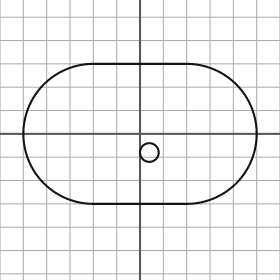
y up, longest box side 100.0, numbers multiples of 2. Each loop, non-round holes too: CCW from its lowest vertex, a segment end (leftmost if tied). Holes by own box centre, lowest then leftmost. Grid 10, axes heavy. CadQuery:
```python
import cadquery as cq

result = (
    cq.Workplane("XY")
    .moveTo(-20.0, -30.0)
    .lineTo(20.0, -30.0)
    .threePointArc((50.0, 0.0), (20.0, 30.0))
    .lineTo(-20.0, 30.0)
    .threePointArc((-50.0, 0.0), (-20.0, -30.0))
    .close()
    .moveTo(4.0, -8.0)
    .circle(4.0)
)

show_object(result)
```